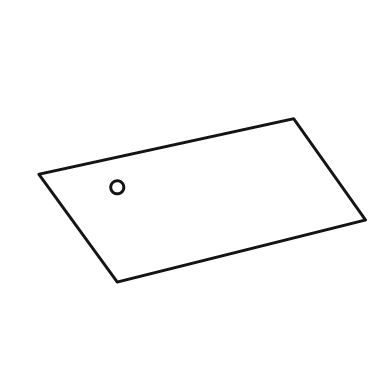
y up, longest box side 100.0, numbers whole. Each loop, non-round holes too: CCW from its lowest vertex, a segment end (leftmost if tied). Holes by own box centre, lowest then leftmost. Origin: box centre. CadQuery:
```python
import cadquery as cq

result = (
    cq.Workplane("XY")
    .moveTo(-26.0, -25.0)
    .lineTo(50.0, -6.0)
    .lineTo(28.0, 25.0)
    .lineTo(-50.0, 8.0)
    .close()
    .moveTo(-26.0, 4.0)
    .circle(2.0)
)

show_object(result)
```